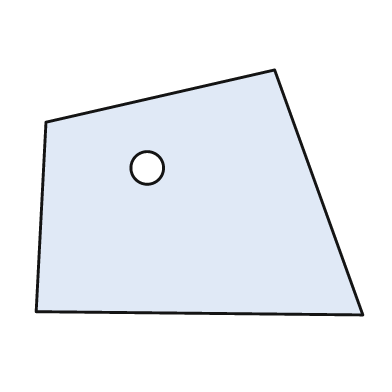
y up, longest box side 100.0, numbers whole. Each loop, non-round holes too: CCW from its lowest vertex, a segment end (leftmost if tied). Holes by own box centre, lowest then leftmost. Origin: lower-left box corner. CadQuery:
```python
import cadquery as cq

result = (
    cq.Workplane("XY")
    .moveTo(100.0, 0.0)
    .lineTo(73.0, 75.0)
    .lineTo(3.0, 59.0)
    .lineTo(0.0, 1.0)
    .close()
    .moveTo(34.0, 45.0)
    .circle(5.0)
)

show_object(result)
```